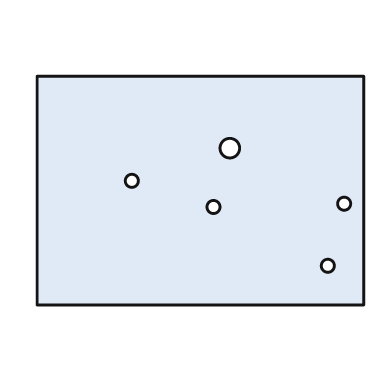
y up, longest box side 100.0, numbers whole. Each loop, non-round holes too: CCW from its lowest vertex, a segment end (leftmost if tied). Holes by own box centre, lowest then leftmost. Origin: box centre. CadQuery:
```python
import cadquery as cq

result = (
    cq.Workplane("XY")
    .moveTo(-50.0, -35.0)
    .lineTo(50.0, -35.0)
    .lineTo(50.0, 35.0)
    .lineTo(-50.0, 35.0)
    .close()
    .moveTo(39.0, -23.0)
    .circle(2.0)
    .moveTo(4.0, -5.0)
    .circle(2.0)
    .moveTo(44.0, -4.0)
    .circle(2.0)
    .moveTo(-21.0, 3.0)
    .circle(2.0)
    .moveTo(9.0, 13.0)
    .circle(3.0)
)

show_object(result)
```